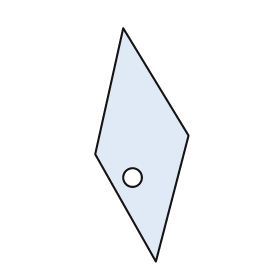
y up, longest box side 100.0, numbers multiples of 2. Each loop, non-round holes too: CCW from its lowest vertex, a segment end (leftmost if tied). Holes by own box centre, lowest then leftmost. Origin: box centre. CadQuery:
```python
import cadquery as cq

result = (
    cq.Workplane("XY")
    .moveTo(6.0, -50.0)
    .lineTo(20.0, 4.0)
    .lineTo(-8.0, 50.0)
    .lineTo(-20.0, -4.0)
    .close()
    .moveTo(-4.0, -14.0)
    .circle(4.0)
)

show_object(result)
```